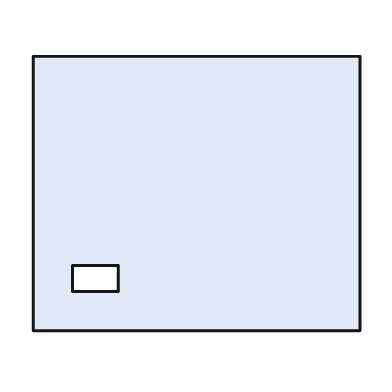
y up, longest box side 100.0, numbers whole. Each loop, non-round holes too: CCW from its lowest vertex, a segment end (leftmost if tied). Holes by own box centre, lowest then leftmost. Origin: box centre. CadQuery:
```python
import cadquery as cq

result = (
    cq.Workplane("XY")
    .moveTo(-50.0, -42.0)
    .lineTo(50.0, -42.0)
    .lineTo(50.0, 42.0)
    .lineTo(-50.0, 42.0)
    .close()
    .moveTo(-38.0, -30.0)
    .lineTo(-24.0, -30.0)
    .lineTo(-24.0, -22.0)
    .lineTo(-38.0, -22.0)
    .close()
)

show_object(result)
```